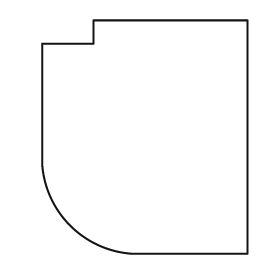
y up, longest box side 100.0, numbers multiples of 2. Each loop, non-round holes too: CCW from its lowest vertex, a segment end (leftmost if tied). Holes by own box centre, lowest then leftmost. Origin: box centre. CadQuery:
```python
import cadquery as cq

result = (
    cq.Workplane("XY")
    .moveTo(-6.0, -50.0)
    .lineTo(44.0, -50.0)
    .lineTo(44.0, 50.0)
    .lineTo(-22.0, 50.0)
    .lineTo(-22.0, 40.0)
    .lineTo(-44.0, 40.0)
    .lineTo(-44.0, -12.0)
    .threePointArc((-32.0, -38.0), (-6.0, -50.0))
    .close()
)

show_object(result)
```